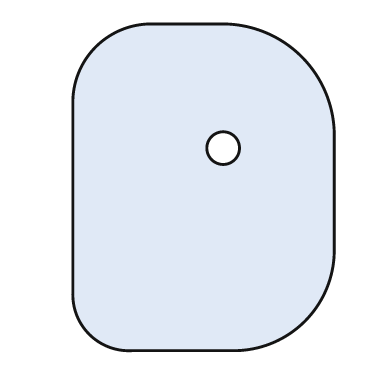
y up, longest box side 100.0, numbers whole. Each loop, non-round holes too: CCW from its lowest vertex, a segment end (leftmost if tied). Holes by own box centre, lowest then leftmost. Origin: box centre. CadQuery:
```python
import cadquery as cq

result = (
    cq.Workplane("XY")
    .moveTo(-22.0, -50.0)
    .lineTo(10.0, -50.0)
    .threePointArc((31.0, -41.0), (40.0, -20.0))
    .lineTo(40.0, 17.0)
    .threePointArc((30.0, 40.0), (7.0, 50.0))
    .lineTo(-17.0, 50.0)
    .threePointArc((-33.0, 43.0), (-40.0, 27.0))
    .lineTo(-40.0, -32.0)
    .threePointArc((-35.0, -45.0), (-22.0, -50.0))
    .close()
    .moveTo(6.0, 12.0)
    .circle(5.0)
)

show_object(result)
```